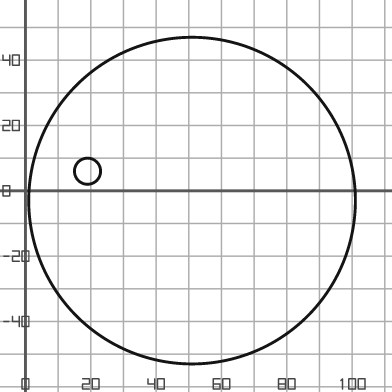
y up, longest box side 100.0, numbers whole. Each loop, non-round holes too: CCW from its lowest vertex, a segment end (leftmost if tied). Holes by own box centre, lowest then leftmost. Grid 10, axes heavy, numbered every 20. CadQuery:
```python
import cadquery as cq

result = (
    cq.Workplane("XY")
    .moveTo(51.0, -3.0)
    .circle(50.0)
    .moveTo(19.0, 6.0)
    .circle(4.0)
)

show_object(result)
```